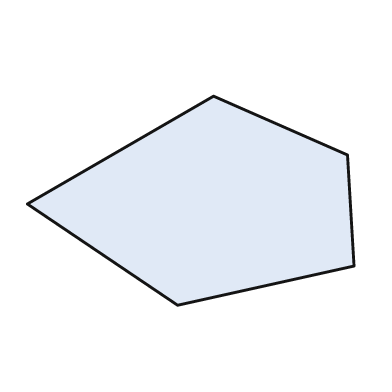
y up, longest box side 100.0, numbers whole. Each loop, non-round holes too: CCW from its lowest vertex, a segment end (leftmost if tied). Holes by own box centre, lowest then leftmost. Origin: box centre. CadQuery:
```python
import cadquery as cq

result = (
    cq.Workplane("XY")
    .moveTo(-4.0, -32.0)
    .lineTo(50.0, -20.0)
    .lineTo(48.0, 14.0)
    .lineTo(7.0, 32.0)
    .lineTo(-50.0, -1.0)
    .close()
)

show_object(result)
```